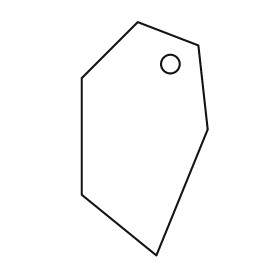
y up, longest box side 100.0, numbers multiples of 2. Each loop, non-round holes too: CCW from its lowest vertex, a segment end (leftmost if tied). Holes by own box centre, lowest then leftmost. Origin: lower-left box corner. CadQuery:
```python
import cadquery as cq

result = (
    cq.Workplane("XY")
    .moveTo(32.0, 0.0)
    .lineTo(54.0, 54.0)
    .lineTo(50.0, 90.0)
    .lineTo(24.0, 100.0)
    .lineTo(0.0, 76.0)
    .lineTo(0.0, 26.0)
    .close()
    .moveTo(38.0, 82.0)
    .circle(4.0)
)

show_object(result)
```